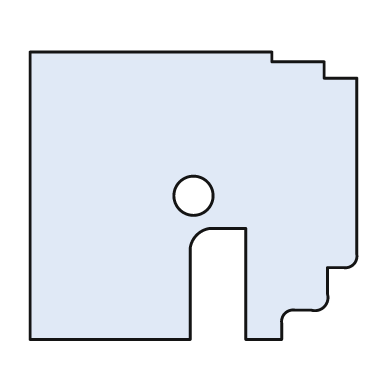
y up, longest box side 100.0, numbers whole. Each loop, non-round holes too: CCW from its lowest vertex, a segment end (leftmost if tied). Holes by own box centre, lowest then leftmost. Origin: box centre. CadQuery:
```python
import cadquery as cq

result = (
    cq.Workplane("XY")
    .moveTo(-50.0, -44.0)
    .lineTo(-1.0, -44.0)
    .lineTo(-1.0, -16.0)
    .threePointArc((1.0, -12.0), (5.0, -10.0))
    .lineTo(16.0, -10.0)
    .lineTo(16.0, -44.0)
    .lineTo(27.0, -44.0)
    .lineTo(27.0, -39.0)
    .threePointArc((28.0, -36.0), (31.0, -35.0))
    .lineTo(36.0, -35.0)
    .threePointArc((40.0, -34.0), (41.0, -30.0))
    .lineTo(41.0, -22.0)
    .lineTo(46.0, -22.0)
    .threePointArc((49.0, -21.0), (50.0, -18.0))
    .lineTo(50.0, 36.0)
    .lineTo(40.0, 36.0)
    .lineTo(40.0, 41.0)
    .lineTo(24.0, 41.0)
    .lineTo(24.0, 44.0)
    .lineTo(-50.0, 44.0)
    .close()
    .moveTo(0.0, 0.0)
    .circle(6.0)
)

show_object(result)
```